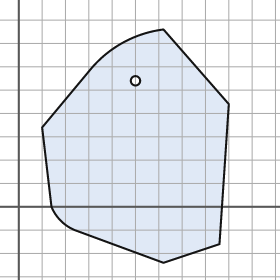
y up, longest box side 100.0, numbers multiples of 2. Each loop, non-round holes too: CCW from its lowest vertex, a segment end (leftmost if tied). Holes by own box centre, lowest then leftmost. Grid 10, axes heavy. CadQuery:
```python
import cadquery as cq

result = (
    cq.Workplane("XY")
    .moveTo(62.0, -24.0)
    .lineTo(86.0, -16.0)
    .lineTo(90.0, 44.0)
    .lineTo(62.0, 76.0)
    .threePointArc((44.0, 70.0), (30.0, 58.0))
    .lineTo(10.0, 34.0)
    .lineTo(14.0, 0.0)
    .threePointArc((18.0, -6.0), (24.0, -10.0))
    .close()
    .moveTo(50.0, 54.0)
    .circle(2.0)
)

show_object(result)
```